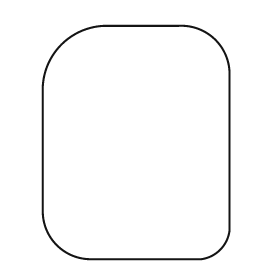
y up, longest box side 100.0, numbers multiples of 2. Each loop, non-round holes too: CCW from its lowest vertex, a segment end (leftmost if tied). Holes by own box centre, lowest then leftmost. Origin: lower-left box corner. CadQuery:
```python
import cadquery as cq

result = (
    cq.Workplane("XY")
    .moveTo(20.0, 0.0)
    .lineTo(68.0, 0.0)
    .threePointArc((76.0, 4.0), (80.0, 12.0))
    .lineTo(80.0, 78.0)
    .threePointArc((74.0, 94.0), (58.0, 100.0))
    .lineTo(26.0, 100.0)
    .threePointArc((8.0, 92.0), (0.0, 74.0))
    .lineTo(0.0, 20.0)
    .threePointArc((6.0, 6.0), (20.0, 0.0))
    .close()
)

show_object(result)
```